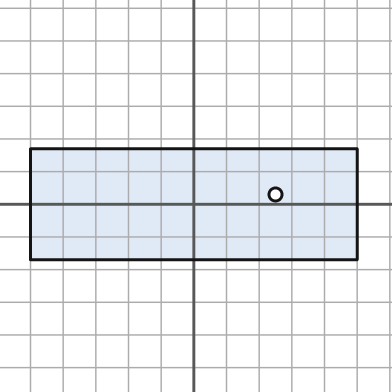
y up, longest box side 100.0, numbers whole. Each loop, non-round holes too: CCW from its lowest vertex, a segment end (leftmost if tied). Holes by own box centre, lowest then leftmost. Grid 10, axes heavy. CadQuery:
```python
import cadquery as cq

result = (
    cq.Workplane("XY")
    .moveTo(-50.0, -17.0)
    .lineTo(50.0, -17.0)
    .lineTo(50.0, 17.0)
    .lineTo(-50.0, 17.0)
    .close()
    .moveTo(25.0, 3.0)
    .circle(2.0)
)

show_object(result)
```